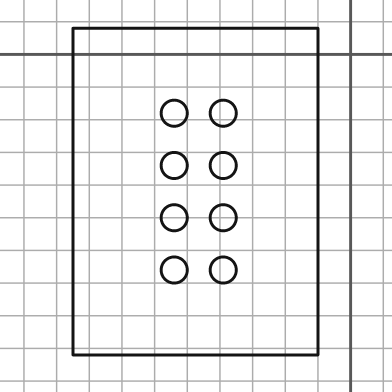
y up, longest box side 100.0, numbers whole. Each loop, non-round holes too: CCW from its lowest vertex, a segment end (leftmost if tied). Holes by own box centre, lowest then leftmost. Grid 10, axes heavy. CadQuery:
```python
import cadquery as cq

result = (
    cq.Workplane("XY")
    .moveTo(-85.0, -92.0)
    .lineTo(-10.0, -92.0)
    .lineTo(-10.0, 8.0)
    .lineTo(-85.0, 8.0)
    .close()
    .moveTo(-54.0, -66.0)
    .circle(4.0)
    .moveTo(-39.0, -66.0)
    .circle(4.0)
    .moveTo(-54.0, -50.0)
    .circle(4.0)
    .moveTo(-39.0, -50.0)
    .circle(4.0)
    .moveTo(-54.0, -34.0)
    .circle(4.0)
    .moveTo(-39.0, -34.0)
    .circle(4.0)
    .moveTo(-54.0, -18.0)
    .circle(4.0)
    .moveTo(-39.0, -18.0)
    .circle(4.0)
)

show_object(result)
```